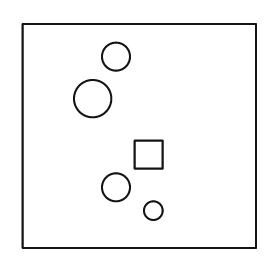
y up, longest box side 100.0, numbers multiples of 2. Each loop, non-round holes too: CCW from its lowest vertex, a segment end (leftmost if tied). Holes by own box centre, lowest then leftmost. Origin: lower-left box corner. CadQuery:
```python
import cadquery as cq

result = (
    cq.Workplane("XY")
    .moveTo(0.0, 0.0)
    .lineTo(100.0, 0.0)
    .lineTo(100.0, 96.0)
    .lineTo(0.0, 96.0)
    .close()
    .moveTo(56.0, 16.0)
    .circle(4.0)
    .moveTo(40.0, 26.0)
    .circle(6.0)
    .moveTo(48.0, 34.0)
    .lineTo(60.0, 34.0)
    .lineTo(60.0, 46.0)
    .lineTo(48.0, 46.0)
    .close()
    .moveTo(30.0, 64.0)
    .circle(8.0)
    .moveTo(40.0, 82.0)
    .circle(6.0)
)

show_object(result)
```